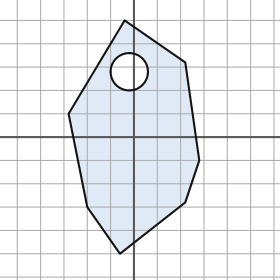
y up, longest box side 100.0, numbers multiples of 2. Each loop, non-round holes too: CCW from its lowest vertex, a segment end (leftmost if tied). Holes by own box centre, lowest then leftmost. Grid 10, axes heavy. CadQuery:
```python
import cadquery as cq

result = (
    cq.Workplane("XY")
    .moveTo(-6.0, -50.0)
    .lineTo(22.0, -28.0)
    .lineTo(28.0, -10.0)
    .lineTo(22.0, 32.0)
    .lineTo(-4.0, 50.0)
    .lineTo(-28.0, 10.0)
    .lineTo(-20.0, -30.0)
    .close()
    .moveTo(-2.0, 28.0)
    .circle(8.0)
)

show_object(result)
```